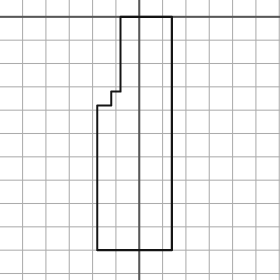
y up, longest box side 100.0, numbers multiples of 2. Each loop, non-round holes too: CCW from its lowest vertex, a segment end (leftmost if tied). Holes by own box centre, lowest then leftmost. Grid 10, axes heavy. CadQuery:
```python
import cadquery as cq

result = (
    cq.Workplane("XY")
    .moveTo(-18.0, -100.0)
    .lineTo(14.0, -100.0)
    .lineTo(14.0, 0.0)
    .lineTo(-8.0, 0.0)
    .lineTo(-8.0, -32.0)
    .lineTo(-12.0, -32.0)
    .lineTo(-12.0, -38.0)
    .lineTo(-18.0, -38.0)
    .close()
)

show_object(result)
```